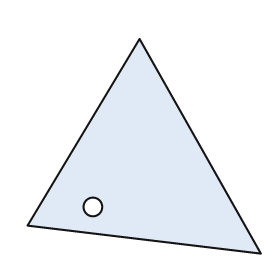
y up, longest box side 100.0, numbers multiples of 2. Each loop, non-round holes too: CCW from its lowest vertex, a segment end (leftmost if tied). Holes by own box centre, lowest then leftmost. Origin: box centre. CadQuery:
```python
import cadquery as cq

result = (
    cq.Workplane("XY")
    .moveTo(50.0, -46.0)
    .lineTo(-2.0, 46.0)
    .lineTo(-50.0, -34.0)
    .close()
    .moveTo(-22.0, -26.0)
    .circle(4.0)
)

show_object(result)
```